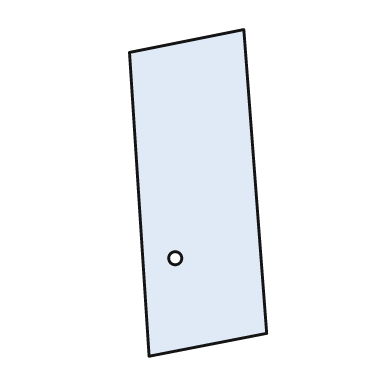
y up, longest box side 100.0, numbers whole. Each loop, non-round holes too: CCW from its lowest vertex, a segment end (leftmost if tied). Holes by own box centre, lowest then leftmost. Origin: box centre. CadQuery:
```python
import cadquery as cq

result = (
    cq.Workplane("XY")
    .moveTo(-15.0, -50.0)
    .lineTo(21.0, -43.0)
    .lineTo(14.0, 50.0)
    .lineTo(-21.0, 43.0)
    .close()
    .moveTo(-7.0, -20.0)
    .circle(2.0)
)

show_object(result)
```